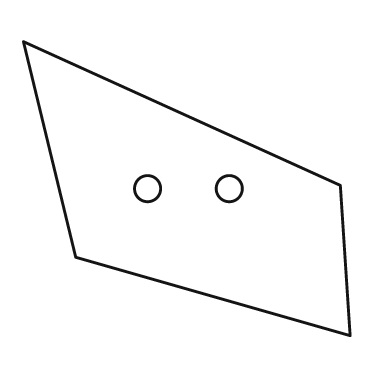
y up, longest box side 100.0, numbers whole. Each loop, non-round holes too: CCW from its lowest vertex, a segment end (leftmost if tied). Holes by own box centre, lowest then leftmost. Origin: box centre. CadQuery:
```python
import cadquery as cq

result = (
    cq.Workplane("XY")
    .moveTo(50.0, -45.0)
    .lineTo(47.0, 1.0)
    .lineTo(-50.0, 45.0)
    .lineTo(-34.0, -21.0)
    .close()
    .moveTo(-12.0, 0.0)
    .circle(4.0)
    .moveTo(13.0, 0.0)
    .circle(4.0)
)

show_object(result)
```